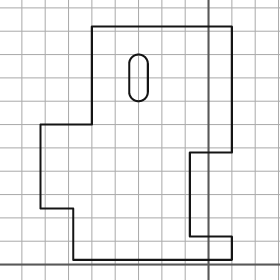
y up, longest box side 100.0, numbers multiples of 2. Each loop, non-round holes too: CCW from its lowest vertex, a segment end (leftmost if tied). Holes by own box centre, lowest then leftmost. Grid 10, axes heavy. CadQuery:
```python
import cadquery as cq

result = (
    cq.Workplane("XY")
    .moveTo(-58.0, 2.0)
    .lineTo(10.0, 2.0)
    .lineTo(10.0, 12.0)
    .lineTo(-8.0, 12.0)
    .lineTo(-8.0, 48.0)
    .lineTo(10.0, 48.0)
    .lineTo(10.0, 102.0)
    .lineTo(-50.0, 102.0)
    .lineTo(-50.0, 60.0)
    .lineTo(-72.0, 60.0)
    .lineTo(-72.0, 24.0)
    .lineTo(-58.0, 24.0)
    .close()
    .moveTo(-34.0, 74.0)
    .threePointArc((-30.0, 70.0), (-26.0, 74.0))
    .lineTo(-26.0, 86.0)
    .threePointArc((-30.0, 90.0), (-34.0, 86.0))
    .close()
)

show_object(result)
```